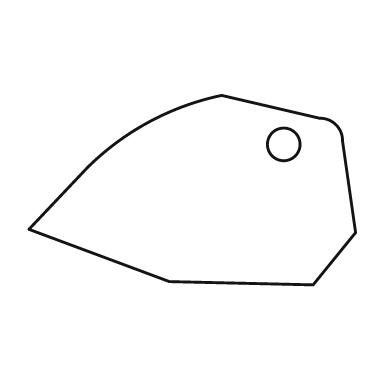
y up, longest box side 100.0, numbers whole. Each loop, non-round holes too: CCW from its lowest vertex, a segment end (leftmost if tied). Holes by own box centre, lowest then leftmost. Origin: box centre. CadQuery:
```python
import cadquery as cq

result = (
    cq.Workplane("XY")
    .moveTo(37.0, -29.0)
    .lineTo(50.0, -13.0)
    .lineTo(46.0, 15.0)
    .threePointArc((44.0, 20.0), (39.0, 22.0))
    .lineTo(9.0, 29.0)
    .threePointArc((-13.0, 21.0), (-32.0, 7.0))
    .lineTo(-50.0, -12.0)
    .lineTo(-7.0, -28.0)
    .close()
    .moveTo(28.0, 14.0)
    .circle(5.0)
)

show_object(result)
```